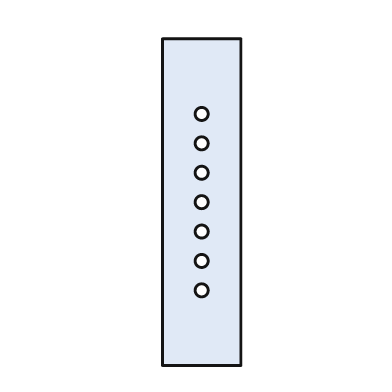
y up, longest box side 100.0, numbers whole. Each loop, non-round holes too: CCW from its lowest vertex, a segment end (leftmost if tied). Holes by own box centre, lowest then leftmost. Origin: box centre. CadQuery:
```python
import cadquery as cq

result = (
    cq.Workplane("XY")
    .moveTo(-12.0, -50.0)
    .lineTo(12.0, -50.0)
    .lineTo(12.0, 50.0)
    .lineTo(-12.0, 50.0)
    .close()
    .moveTo(0.0, -27.0)
    .circle(2.0)
    .moveTo(0.0, -18.0)
    .circle(2.0)
    .moveTo(0.0, -9.0)
    .circle(2.0)
    .moveTo(0.0, 0.0)
    .circle(2.0)
    .moveTo(0.0, 9.0)
    .circle(2.0)
    .moveTo(0.0, 18.0)
    .circle(2.0)
    .moveTo(0.0, 27.0)
    .circle(2.0)
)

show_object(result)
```